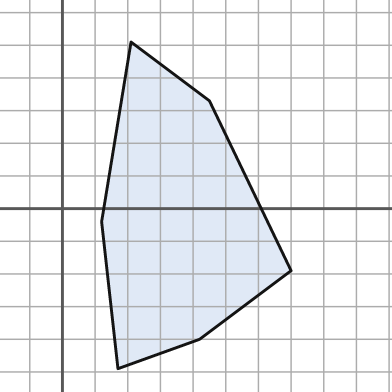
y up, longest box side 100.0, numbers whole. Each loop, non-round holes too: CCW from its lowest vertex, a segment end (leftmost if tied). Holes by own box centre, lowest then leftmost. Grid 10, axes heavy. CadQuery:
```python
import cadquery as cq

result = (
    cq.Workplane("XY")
    .moveTo(17.0, -49.0)
    .lineTo(42.0, -40.0)
    .lineTo(70.0, -19.0)
    .lineTo(45.0, 33.0)
    .lineTo(21.0, 51.0)
    .lineTo(12.0, -4.0)
    .close()
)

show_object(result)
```